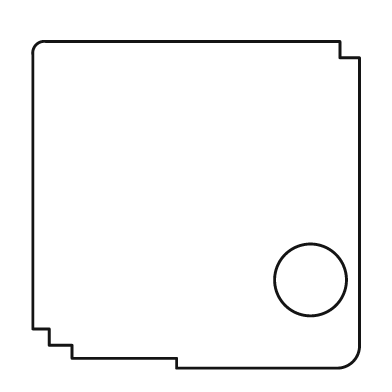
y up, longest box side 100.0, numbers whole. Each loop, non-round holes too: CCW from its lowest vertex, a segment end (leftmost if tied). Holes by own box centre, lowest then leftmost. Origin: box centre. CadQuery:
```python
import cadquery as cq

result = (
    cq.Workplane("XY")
    .moveTo(-6.0, -50.0)
    .lineTo(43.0, -50.0)
    .threePointArc((48.0, -48.0), (50.0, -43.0))
    .lineTo(50.0, 45.0)
    .lineTo(44.0, 45.0)
    .lineTo(44.0, 50.0)
    .lineTo(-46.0, 50.0)
    .threePointArc((-49.0, 49.0), (-50.0, 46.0))
    .lineTo(-50.0, -38.0)
    .lineTo(-45.0, -38.0)
    .lineTo(-45.0, -43.0)
    .lineTo(-38.0, -43.0)
    .lineTo(-38.0, -47.0)
    .lineTo(-6.0, -47.0)
    .close()
    .moveTo(35.0, -23.0)
    .circle(11.0)
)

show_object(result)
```